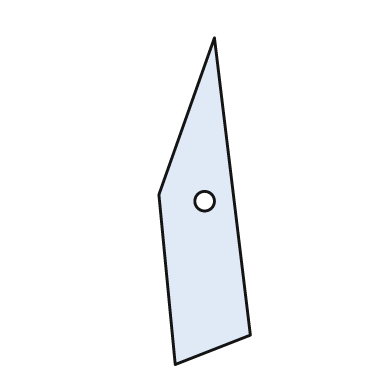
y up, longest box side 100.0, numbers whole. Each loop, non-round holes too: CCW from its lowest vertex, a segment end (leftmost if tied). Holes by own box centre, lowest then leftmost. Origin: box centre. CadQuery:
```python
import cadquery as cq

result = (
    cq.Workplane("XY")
    .moveTo(-9.0, -50.0)
    .lineTo(14.0, -41.0)
    .lineTo(3.0, 50.0)
    .lineTo(-14.0, 2.0)
    .close()
    .moveTo(0.0, 0.0)
    .circle(3.0)
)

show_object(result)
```